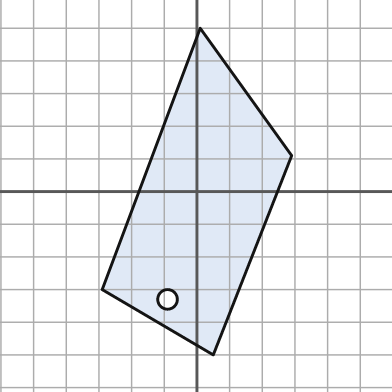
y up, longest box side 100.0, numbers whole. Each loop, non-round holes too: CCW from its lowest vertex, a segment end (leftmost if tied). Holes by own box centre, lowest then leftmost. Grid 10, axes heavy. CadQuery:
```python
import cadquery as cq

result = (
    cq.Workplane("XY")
    .moveTo(5.0, -50.0)
    .lineTo(29.0, 11.0)
    .lineTo(1.0, 50.0)
    .lineTo(-29.0, -30.0)
    .close()
    .moveTo(-9.0, -33.0)
    .circle(3.0)
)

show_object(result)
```